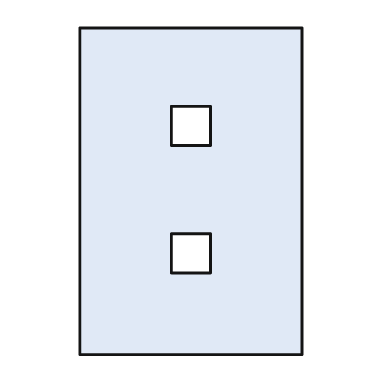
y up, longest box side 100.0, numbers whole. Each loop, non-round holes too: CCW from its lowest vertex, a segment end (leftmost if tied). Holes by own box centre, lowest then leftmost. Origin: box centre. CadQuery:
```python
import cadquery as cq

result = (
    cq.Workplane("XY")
    .moveTo(-34.0, -50.0)
    .lineTo(34.0, -50.0)
    .lineTo(34.0, 50.0)
    .lineTo(-34.0, 50.0)
    .close()
    .moveTo(-6.0, -25.0)
    .lineTo(6.0, -25.0)
    .lineTo(6.0, -13.0)
    .lineTo(-6.0, -13.0)
    .close()
    .moveTo(-6.0, 14.0)
    .lineTo(6.0, 14.0)
    .lineTo(6.0, 26.0)
    .lineTo(-6.0, 26.0)
    .close()
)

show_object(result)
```